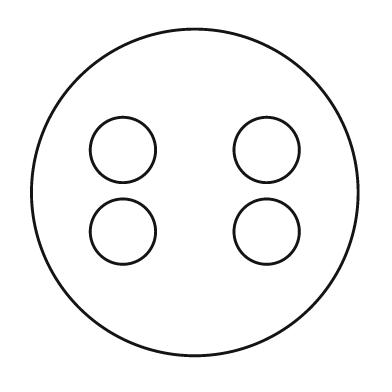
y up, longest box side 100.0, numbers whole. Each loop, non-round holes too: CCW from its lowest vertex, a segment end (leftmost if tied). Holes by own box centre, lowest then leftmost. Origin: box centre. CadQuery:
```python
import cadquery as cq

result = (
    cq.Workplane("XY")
    .moveTo(0.0, 0.0)
    .circle(50.0)
    .moveTo(-22.0, -12.0)
    .circle(10.0)
    .moveTo(22.0, -12.0)
    .circle(10.0)
    .moveTo(-22.0, 13.0)
    .circle(10.0)
    .moveTo(22.0, 13.0)
    .circle(10.0)
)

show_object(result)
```